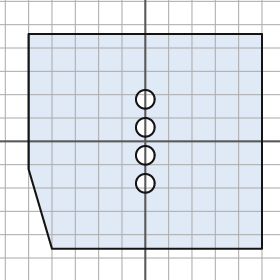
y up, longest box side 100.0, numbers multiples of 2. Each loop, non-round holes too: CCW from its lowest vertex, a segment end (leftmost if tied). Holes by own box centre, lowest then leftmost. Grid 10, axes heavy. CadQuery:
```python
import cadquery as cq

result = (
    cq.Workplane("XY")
    .moveTo(-40.0, -46.0)
    .lineTo(50.0, -46.0)
    .lineTo(50.0, 46.0)
    .lineTo(-50.0, 46.0)
    .lineTo(-50.0, -12.0)
    .close()
    .moveTo(0.0, -18.0)
    .circle(4.0)
    .moveTo(0.0, -6.0)
    .circle(4.0)
    .moveTo(0.0, 6.0)
    .circle(4.0)
    .moveTo(0.0, 18.0)
    .circle(4.0)
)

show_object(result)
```